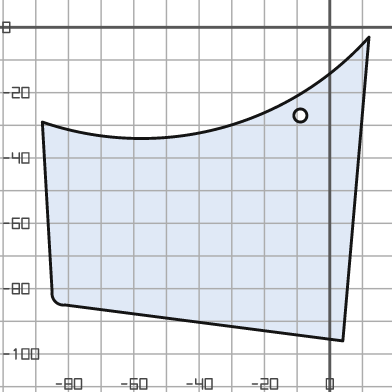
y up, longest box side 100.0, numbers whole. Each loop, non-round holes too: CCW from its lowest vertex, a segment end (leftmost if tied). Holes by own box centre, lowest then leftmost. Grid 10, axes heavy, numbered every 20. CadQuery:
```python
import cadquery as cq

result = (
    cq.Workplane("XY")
    .moveTo(4.0, -96.0)
    .lineTo(12.0, -3.0)
    .threePointArc((-34.0, -31.0), (-88.0, -29.0))
    .lineTo(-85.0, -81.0)
    .threePointArc((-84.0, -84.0), (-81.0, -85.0))
    .close()
    .moveTo(-9.0, -27.0)
    .circle(2.0)
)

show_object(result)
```